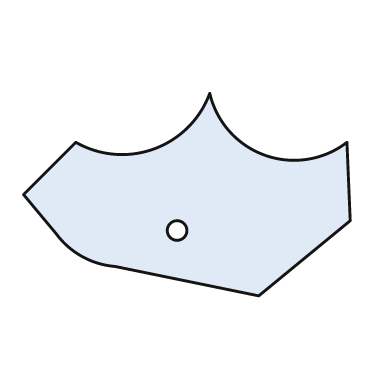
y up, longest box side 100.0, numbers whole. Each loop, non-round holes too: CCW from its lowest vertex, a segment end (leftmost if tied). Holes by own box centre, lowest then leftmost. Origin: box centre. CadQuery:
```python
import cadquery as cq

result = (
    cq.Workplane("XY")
    .moveTo(22.0, -31.0)
    .lineTo(50.0, -8.0)
    .lineTo(49.0, 16.0)
    .threePointArc((24.0, 12.0), (7.0, 31.0))
    .threePointArc((-10.0, 14.0), (-34.0, 16.0))
    .lineTo(-50.0, 0.0)
    .lineTo(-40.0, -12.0)
    .threePointArc((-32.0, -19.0), (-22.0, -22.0))
    .close()
    .moveTo(-3.0, -11.0)
    .circle(3.0)
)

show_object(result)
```